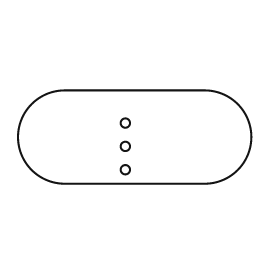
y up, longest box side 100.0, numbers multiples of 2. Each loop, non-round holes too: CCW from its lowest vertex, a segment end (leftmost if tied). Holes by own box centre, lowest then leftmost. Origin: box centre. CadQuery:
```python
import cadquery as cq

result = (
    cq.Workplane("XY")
    .moveTo(-30.0, -20.0)
    .lineTo(30.0, -20.0)
    .threePointArc((50.0, 0.0), (30.0, 20.0))
    .lineTo(-30.0, 20.0)
    .threePointArc((-50.0, 0.0), (-30.0, -20.0))
    .close()
    .moveTo(-4.0, -14.0)
    .circle(2.0)
    .moveTo(-4.0, -4.0)
    .circle(2.0)
    .moveTo(-4.0, 6.0)
    .circle(2.0)
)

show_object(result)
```